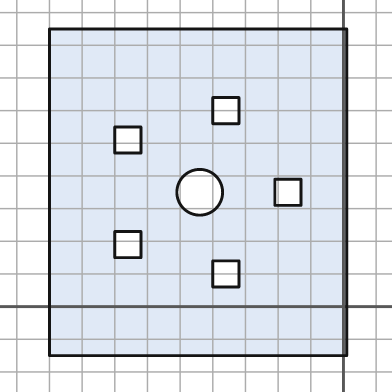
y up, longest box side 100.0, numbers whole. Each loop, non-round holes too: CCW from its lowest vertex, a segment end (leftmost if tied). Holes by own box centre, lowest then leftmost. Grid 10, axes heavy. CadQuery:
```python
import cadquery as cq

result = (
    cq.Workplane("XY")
    .moveTo(-90.0, -15.0)
    .lineTo(1.0, -15.0)
    .lineTo(1.0, 85.0)
    .lineTo(-90.0, 85.0)
    .close()
    .moveTo(-40.0, 6.0)
    .lineTo(-32.0, 6.0)
    .lineTo(-32.0, 14.0)
    .lineTo(-40.0, 14.0)
    .close()
    .moveTo(-70.0, 15.0)
    .lineTo(-62.0, 15.0)
    .lineTo(-62.0, 23.0)
    .lineTo(-70.0, 23.0)
    .close()
    .moveTo(-44.0, 35.0)
    .circle(7.0)
    .moveTo(-21.0, 31.0)
    .lineTo(-13.0, 31.0)
    .lineTo(-13.0, 39.0)
    .lineTo(-21.0, 39.0)
    .close()
    .moveTo(-70.0, 47.0)
    .lineTo(-62.0, 47.0)
    .lineTo(-62.0, 55.0)
    .lineTo(-70.0, 55.0)
    .close()
    .moveTo(-40.0, 56.0)
    .lineTo(-32.0, 56.0)
    .lineTo(-32.0, 64.0)
    .lineTo(-40.0, 64.0)
    .close()
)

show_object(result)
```